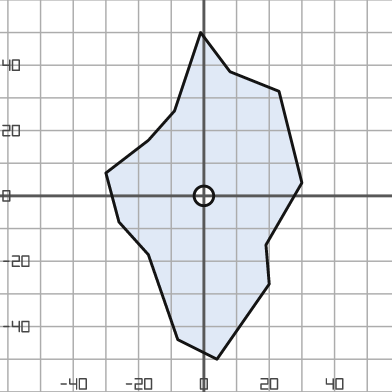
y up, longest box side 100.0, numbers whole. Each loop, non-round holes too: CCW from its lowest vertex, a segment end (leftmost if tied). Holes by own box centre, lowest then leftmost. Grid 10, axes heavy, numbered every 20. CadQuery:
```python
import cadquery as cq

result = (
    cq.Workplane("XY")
    .moveTo(4.0, -50.0)
    .lineTo(20.0, -27.0)
    .lineTo(19.0, -15.0)
    .lineTo(30.0, 4.0)
    .lineTo(23.0, 32.0)
    .lineTo(8.0, 38.0)
    .lineTo(-1.0, 50.0)
    .lineTo(-9.0, 26.0)
    .lineTo(-17.0, 17.0)
    .lineTo(-30.0, 7.0)
    .lineTo(-26.0, -8.0)
    .lineTo(-17.0, -18.0)
    .lineTo(-8.0, -44.0)
    .close()
    .moveTo(0.0, 0.0)
    .circle(3.0)
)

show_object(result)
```